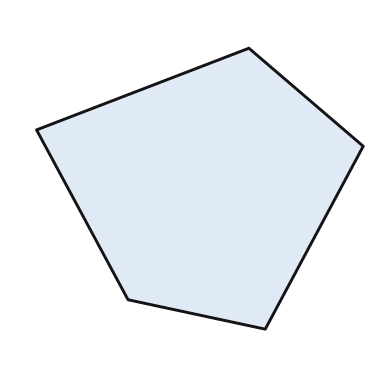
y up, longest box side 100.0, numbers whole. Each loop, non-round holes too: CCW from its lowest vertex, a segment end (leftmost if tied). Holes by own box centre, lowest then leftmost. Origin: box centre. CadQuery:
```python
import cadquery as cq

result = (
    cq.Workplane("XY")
    .moveTo(20.0, -43.0)
    .lineTo(50.0, 13.0)
    .lineTo(15.0, 43.0)
    .lineTo(-50.0, 18.0)
    .lineTo(-22.0, -34.0)
    .close()
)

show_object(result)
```